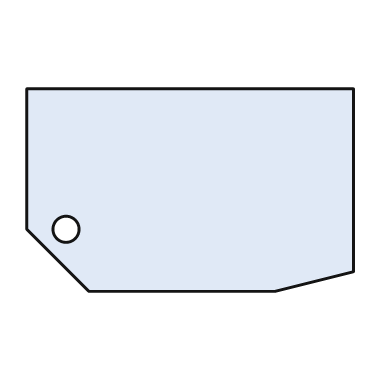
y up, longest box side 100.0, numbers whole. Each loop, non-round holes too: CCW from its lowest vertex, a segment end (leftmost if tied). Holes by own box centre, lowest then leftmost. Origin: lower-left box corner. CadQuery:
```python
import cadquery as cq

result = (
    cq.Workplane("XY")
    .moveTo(19.0, 0.0)
    .lineTo(76.0, 0.0)
    .lineTo(100.0, 6.0)
    .lineTo(100.0, 62.0)
    .lineTo(0.0, 62.0)
    .lineTo(0.0, 19.0)
    .close()
    .moveTo(12.0, 19.0)
    .circle(4.0)
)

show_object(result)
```